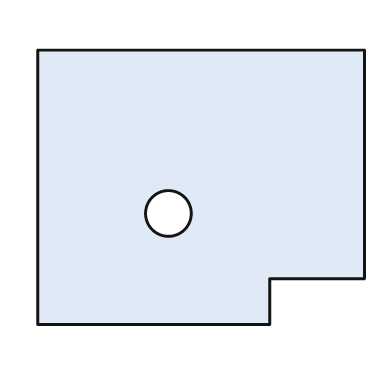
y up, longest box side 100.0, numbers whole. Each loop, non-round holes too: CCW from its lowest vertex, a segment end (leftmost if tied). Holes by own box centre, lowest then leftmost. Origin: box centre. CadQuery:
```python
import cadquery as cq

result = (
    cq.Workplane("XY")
    .moveTo(-50.0, -42.0)
    .lineTo(21.0, -42.0)
    .lineTo(21.0, -28.0)
    .lineTo(50.0, -28.0)
    .lineTo(50.0, 42.0)
    .lineTo(-50.0, 42.0)
    .close()
    .moveTo(-10.0, -8.0)
    .circle(7.0)
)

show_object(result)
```